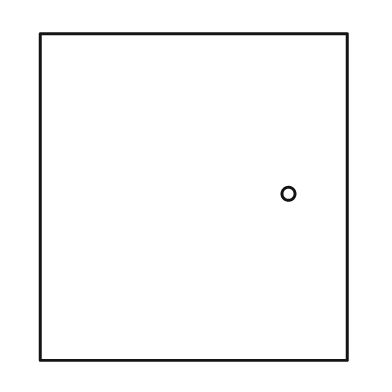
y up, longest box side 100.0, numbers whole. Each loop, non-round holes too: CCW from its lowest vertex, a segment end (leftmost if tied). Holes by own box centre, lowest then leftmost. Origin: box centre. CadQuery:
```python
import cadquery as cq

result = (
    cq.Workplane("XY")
    .moveTo(-47.0, -50.0)
    .lineTo(47.0, -50.0)
    .lineTo(47.0, 50.0)
    .lineTo(-47.0, 50.0)
    .close()
    .moveTo(29.0, 1.0)
    .circle(2.0)
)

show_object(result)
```